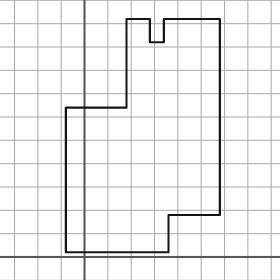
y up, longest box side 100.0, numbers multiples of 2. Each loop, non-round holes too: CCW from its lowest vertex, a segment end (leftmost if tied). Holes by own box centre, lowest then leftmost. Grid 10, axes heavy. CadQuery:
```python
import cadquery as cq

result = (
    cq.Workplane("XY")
    .moveTo(-8.0, 2.0)
    .lineTo(36.0, 2.0)
    .lineTo(36.0, 18.0)
    .lineTo(58.0, 18.0)
    .lineTo(58.0, 102.0)
    .lineTo(34.0, 102.0)
    .lineTo(34.0, 92.0)
    .lineTo(28.0, 92.0)
    .lineTo(28.0, 102.0)
    .lineTo(18.0, 102.0)
    .lineTo(18.0, 64.0)
    .lineTo(-8.0, 64.0)
    .close()
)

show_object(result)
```